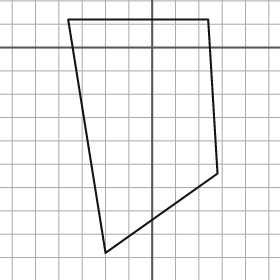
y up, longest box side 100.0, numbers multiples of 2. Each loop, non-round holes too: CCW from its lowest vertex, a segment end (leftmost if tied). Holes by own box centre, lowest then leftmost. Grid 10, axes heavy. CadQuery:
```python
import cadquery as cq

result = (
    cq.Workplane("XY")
    .moveTo(-20.0, -88.0)
    .lineTo(28.0, -54.0)
    .lineTo(24.0, 12.0)
    .lineTo(-36.0, 12.0)
    .close()
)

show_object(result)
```